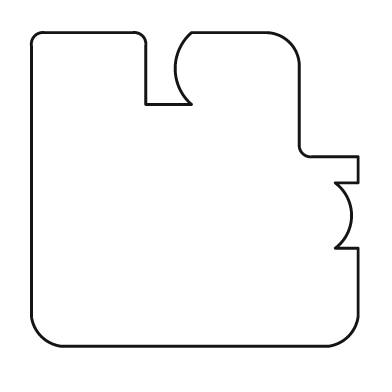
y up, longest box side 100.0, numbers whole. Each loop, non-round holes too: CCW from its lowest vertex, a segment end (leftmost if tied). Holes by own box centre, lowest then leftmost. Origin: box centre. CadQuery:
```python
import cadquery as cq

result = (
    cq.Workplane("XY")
    .moveTo(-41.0, -48.0)
    .lineTo(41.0, -48.0)
    .threePointArc((47.0, -45.0), (50.0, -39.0))
    .lineTo(50.0, -18.0)
    .lineTo(43.0, -18.0)
    .threePointArc((48.0, -8.0), (43.0, 2.0))
    .lineTo(50.0, 2.0)
    .lineTo(50.0, 10.0)
    .lineTo(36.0, 10.0)
    .threePointArc((33.0, 11.0), (32.0, 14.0))
    .lineTo(32.0, 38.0)
    .threePointArc((29.0, 45.0), (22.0, 48.0))
    .lineTo(-1.0, 48.0)
    .threePointArc((-6.0, 37.0), (-1.0, 26.0))
    .lineTo(-15.0, 26.0)
    .lineTo(-15.0, 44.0)
    .threePointArc((-16.0, 47.0), (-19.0, 48.0))
    .lineTo(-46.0, 48.0)
    .threePointArc((-49.0, 47.0), (-50.0, 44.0))
    .lineTo(-50.0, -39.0)
    .threePointArc((-47.0, -45.0), (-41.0, -48.0))
    .close()
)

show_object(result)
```